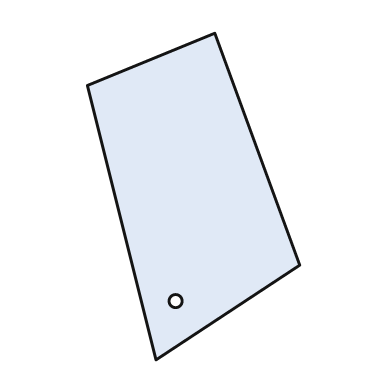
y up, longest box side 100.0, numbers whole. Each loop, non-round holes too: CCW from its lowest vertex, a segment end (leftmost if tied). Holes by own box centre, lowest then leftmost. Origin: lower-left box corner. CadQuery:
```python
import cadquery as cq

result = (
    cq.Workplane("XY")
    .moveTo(21.0, 0.0)
    .lineTo(65.0, 29.0)
    .lineTo(39.0, 100.0)
    .lineTo(0.0, 84.0)
    .close()
    .moveTo(27.0, 18.0)
    .circle(2.0)
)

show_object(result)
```